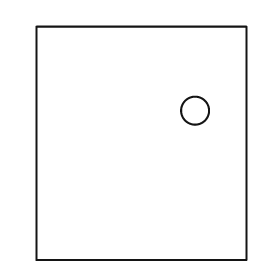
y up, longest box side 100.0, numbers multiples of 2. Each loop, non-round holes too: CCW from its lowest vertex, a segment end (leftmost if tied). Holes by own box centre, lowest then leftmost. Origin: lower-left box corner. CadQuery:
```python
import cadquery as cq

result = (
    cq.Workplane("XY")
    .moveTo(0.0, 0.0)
    .lineTo(90.0, 0.0)
    .lineTo(90.0, 100.0)
    .lineTo(0.0, 100.0)
    .close()
    .moveTo(68.0, 64.0)
    .circle(6.0)
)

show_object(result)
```